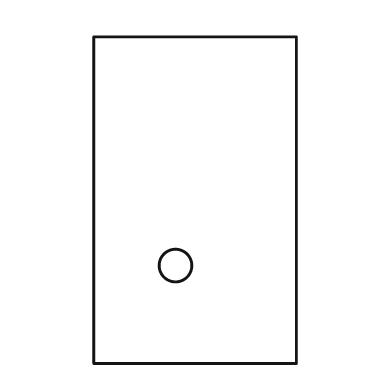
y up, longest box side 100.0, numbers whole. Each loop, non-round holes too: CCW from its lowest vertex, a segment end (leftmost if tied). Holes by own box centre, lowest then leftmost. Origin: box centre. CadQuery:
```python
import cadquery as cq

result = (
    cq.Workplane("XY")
    .moveTo(-31.0, -50.0)
    .lineTo(31.0, -50.0)
    .lineTo(31.0, 50.0)
    .lineTo(-31.0, 50.0)
    .close()
    .moveTo(-6.0, -20.0)
    .circle(5.0)
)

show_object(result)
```